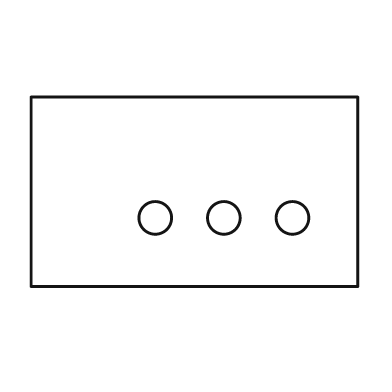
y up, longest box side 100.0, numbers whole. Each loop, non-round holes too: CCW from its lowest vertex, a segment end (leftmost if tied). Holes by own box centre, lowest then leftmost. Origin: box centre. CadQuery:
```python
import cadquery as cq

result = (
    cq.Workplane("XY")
    .moveTo(-50.0, -29.0)
    .lineTo(50.0, -29.0)
    .lineTo(50.0, 29.0)
    .lineTo(-50.0, 29.0)
    .close()
    .moveTo(-12.0, -8.0)
    .circle(5.0)
    .moveTo(9.0, -8.0)
    .circle(5.0)
    .moveTo(30.0, -8.0)
    .circle(5.0)
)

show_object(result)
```